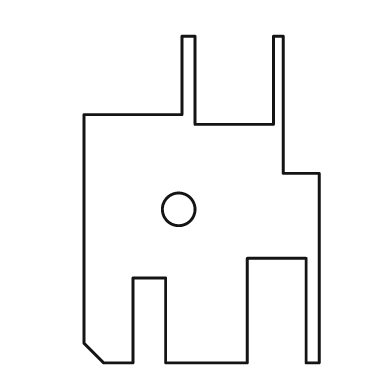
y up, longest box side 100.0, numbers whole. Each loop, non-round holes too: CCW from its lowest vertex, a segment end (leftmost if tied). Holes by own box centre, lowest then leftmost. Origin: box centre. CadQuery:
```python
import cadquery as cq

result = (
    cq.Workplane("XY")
    .moveTo(-30.0, -50.0)
    .lineTo(-21.0, -50.0)
    .lineTo(-21.0, -24.0)
    .lineTo(-11.0, -24.0)
    .lineTo(-11.0, -50.0)
    .lineTo(14.0, -50.0)
    .lineTo(14.0, -18.0)
    .lineTo(32.0, -18.0)
    .lineTo(32.0, -50.0)
    .lineTo(36.0, -50.0)
    .lineTo(36.0, 8.0)
    .lineTo(25.0, 8.0)
    .lineTo(25.0, 50.0)
    .lineTo(22.0, 50.0)
    .lineTo(22.0, 23.0)
    .lineTo(-2.0, 23.0)
    .lineTo(-2.0, 50.0)
    .lineTo(-6.0, 50.0)
    .lineTo(-6.0, 26.0)
    .lineTo(-36.0, 26.0)
    .lineTo(-36.0, -44.0)
    .close()
    .moveTo(-7.0, -3.0)
    .circle(5.0)
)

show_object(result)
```